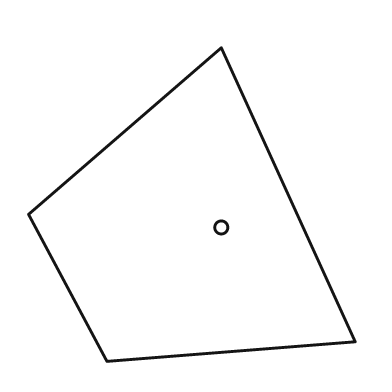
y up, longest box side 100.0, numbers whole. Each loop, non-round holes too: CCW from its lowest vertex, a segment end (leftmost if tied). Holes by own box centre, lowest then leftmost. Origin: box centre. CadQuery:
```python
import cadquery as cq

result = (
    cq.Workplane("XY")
    .moveTo(-26.0, -48.0)
    .lineTo(50.0, -42.0)
    .lineTo(9.0, 48.0)
    .lineTo(-50.0, -3.0)
    .close()
    .moveTo(9.0, -7.0)
    .circle(2.0)
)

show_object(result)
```